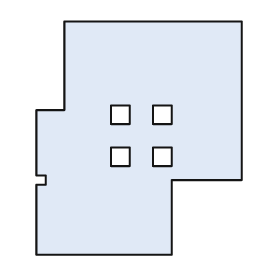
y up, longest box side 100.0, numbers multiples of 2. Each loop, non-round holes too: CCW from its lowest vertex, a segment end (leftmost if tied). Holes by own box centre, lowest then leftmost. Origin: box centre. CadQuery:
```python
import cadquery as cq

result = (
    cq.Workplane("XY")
    .moveTo(-44.0, -50.0)
    .lineTo(14.0, -50.0)
    .lineTo(14.0, -18.0)
    .lineTo(44.0, -18.0)
    .lineTo(44.0, 50.0)
    .lineTo(-32.0, 50.0)
    .lineTo(-32.0, 12.0)
    .lineTo(-44.0, 12.0)
    .lineTo(-44.0, -16.0)
    .lineTo(-40.0, -16.0)
    .lineTo(-40.0, -20.0)
    .lineTo(-44.0, -20.0)
    .close()
    .moveTo(-12.0, -12.0)
    .lineTo(-4.0, -12.0)
    .lineTo(-4.0, -4.0)
    .lineTo(-12.0, -4.0)
    .close()
    .moveTo(6.0, -12.0)
    .lineTo(14.0, -12.0)
    .lineTo(14.0, -4.0)
    .lineTo(6.0, -4.0)
    .close()
    .moveTo(-12.0, 6.0)
    .lineTo(-4.0, 6.0)
    .lineTo(-4.0, 14.0)
    .lineTo(-12.0, 14.0)
    .close()
    .moveTo(6.0, 6.0)
    .lineTo(14.0, 6.0)
    .lineTo(14.0, 14.0)
    .lineTo(6.0, 14.0)
    .close()
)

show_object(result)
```